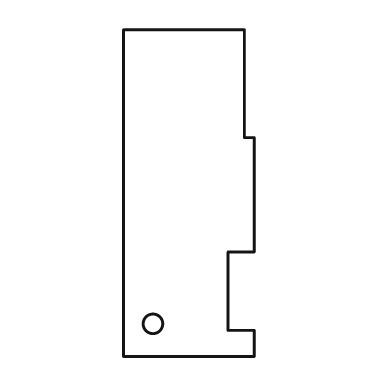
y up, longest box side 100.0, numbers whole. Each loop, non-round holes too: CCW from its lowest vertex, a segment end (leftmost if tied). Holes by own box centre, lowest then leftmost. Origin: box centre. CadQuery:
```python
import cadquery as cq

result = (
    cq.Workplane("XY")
    .moveTo(-20.0, -50.0)
    .lineTo(20.0, -50.0)
    .lineTo(20.0, -42.0)
    .lineTo(12.0, -42.0)
    .lineTo(12.0, -18.0)
    .lineTo(20.0, -18.0)
    .lineTo(20.0, 17.0)
    .lineTo(17.0, 17.0)
    .lineTo(17.0, 50.0)
    .lineTo(-20.0, 50.0)
    .close()
    .moveTo(-11.0, -40.0)
    .circle(3.0)
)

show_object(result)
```